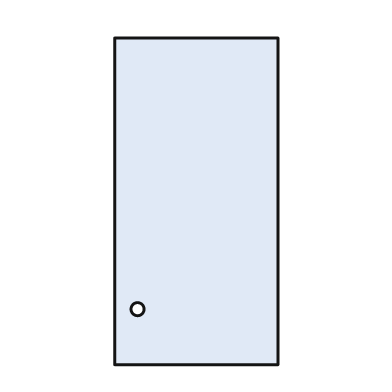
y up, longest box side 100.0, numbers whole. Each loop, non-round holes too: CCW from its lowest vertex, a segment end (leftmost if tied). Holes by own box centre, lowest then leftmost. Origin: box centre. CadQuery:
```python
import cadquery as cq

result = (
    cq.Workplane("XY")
    .moveTo(-25.0, -50.0)
    .lineTo(25.0, -50.0)
    .lineTo(25.0, 50.0)
    .lineTo(-25.0, 50.0)
    .close()
    .moveTo(-18.0, -33.0)
    .circle(2.0)
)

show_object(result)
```